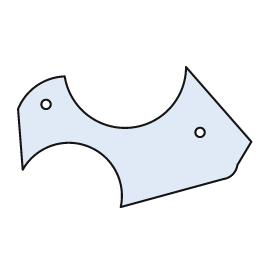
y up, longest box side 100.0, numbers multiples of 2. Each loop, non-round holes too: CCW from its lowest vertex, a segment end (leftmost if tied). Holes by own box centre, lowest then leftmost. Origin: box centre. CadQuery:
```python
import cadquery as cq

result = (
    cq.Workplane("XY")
    .moveTo(-6.0, -30.0)
    .lineTo(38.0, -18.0)
    .threePointArc((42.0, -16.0), (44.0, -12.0))
    .lineTo(50.0, -2.0)
    .lineTo(22.0, 30.0)
    .threePointArc((-2.0, 4.0), (-30.0, 26.0))
    .threePointArc((-42.0, 22.0), (-50.0, 12.0))
    .lineTo(-48.0, -14.0)
    .threePointArc((-20.0, -4.0), (-6.0, -30.0))
    .close()
    .moveTo(28.0, 2.0)
    .circle(2.0)
    .moveTo(-38.0, 14.0)
    .circle(2.0)
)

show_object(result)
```